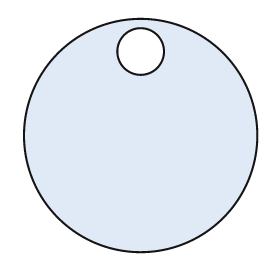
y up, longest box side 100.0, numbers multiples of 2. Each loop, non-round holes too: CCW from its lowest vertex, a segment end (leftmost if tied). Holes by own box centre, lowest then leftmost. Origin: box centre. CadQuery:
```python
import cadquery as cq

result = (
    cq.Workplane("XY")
    .moveTo(0.0, 0.0)
    .circle(50.0)
    .moveTo(0.0, 36.0)
    .circle(10.0)
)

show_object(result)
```